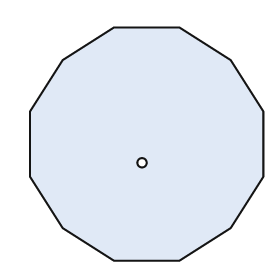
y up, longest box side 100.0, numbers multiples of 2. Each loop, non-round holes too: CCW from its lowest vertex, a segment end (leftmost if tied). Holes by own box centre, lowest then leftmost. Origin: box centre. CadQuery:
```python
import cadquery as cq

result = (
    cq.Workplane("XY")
    .moveTo(-14.0, -50.0)
    .lineTo(14.0, -50.0)
    .lineTo(36.0, -36.0)
    .lineTo(50.0, -14.0)
    .lineTo(50.0, 14.0)
    .lineTo(36.0, 36.0)
    .lineTo(14.0, 50.0)
    .lineTo(-14.0, 50.0)
    .lineTo(-36.0, 36.0)
    .lineTo(-50.0, 14.0)
    .lineTo(-50.0, -14.0)
    .lineTo(-36.0, -36.0)
    .close()
    .moveTo(-2.0, -8.0)
    .circle(2.0)
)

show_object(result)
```